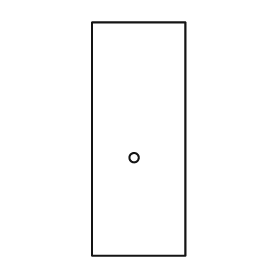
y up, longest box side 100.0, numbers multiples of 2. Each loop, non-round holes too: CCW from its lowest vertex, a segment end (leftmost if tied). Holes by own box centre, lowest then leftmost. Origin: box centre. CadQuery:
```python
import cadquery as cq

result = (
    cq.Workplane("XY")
    .moveTo(-20.0, -50.0)
    .lineTo(20.0, -50.0)
    .lineTo(20.0, 50.0)
    .lineTo(-20.0, 50.0)
    .close()
    .moveTo(-2.0, -8.0)
    .circle(2.0)
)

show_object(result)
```